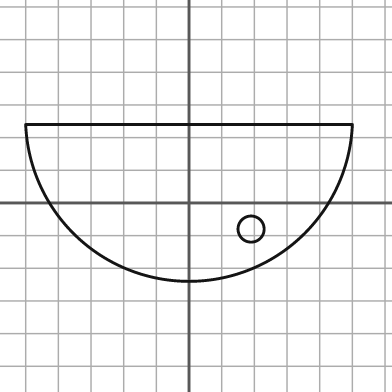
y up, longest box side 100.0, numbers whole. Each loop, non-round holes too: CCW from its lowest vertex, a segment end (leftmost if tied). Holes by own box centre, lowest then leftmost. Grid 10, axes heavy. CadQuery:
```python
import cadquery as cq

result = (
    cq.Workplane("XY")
    .moveTo(-50.0, 24.0)
    .threePointArc((0.0, -24.0), (50.0, 24.0))
    .close()
    .moveTo(19.0, -8.0)
    .circle(4.0)
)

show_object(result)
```